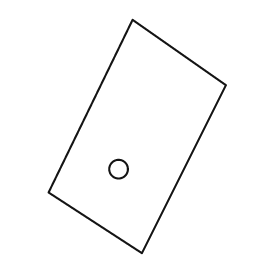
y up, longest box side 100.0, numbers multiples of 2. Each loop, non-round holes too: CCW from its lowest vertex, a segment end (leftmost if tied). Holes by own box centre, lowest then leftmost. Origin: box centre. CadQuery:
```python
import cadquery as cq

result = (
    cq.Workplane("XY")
    .moveTo(2.0, -50.0)
    .lineTo(38.0, 22.0)
    .lineTo(-2.0, 50.0)
    .lineTo(-38.0, -24.0)
    .close()
    .moveTo(-8.0, -14.0)
    .circle(4.0)
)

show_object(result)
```